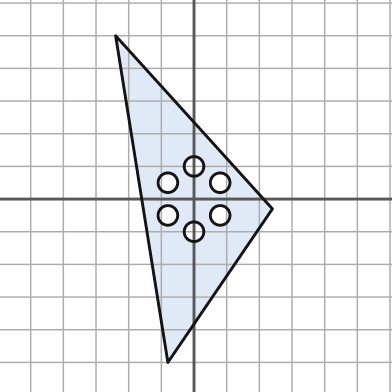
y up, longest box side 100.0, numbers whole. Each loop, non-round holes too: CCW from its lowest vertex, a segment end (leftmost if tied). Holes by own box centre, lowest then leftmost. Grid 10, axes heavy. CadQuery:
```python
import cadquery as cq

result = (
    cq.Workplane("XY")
    .moveTo(-8.0, -50.0)
    .lineTo(24.0, -3.0)
    .lineTo(-24.0, 50.0)
    .close()
    .moveTo(0.0, -10.0)
    .circle(3.0)
    .moveTo(-8.0, -5.0)
    .circle(3.0)
    .moveTo(8.0, -5.0)
    .circle(3.0)
    .moveTo(-8.0, 5.0)
    .circle(3.0)
    .moveTo(8.0, 5.0)
    .circle(3.0)
    .moveTo(0.0, 10.0)
    .circle(3.0)
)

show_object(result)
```